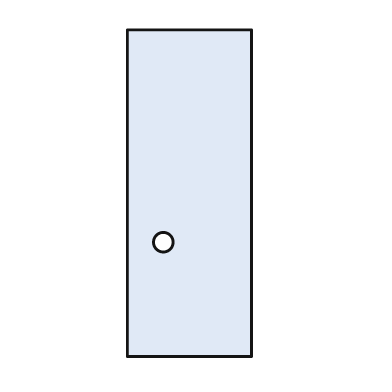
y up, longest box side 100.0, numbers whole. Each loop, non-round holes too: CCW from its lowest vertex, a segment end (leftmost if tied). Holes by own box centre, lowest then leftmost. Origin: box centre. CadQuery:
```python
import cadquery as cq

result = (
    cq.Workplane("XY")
    .moveTo(-19.0, -50.0)
    .lineTo(19.0, -50.0)
    .lineTo(19.0, 50.0)
    .lineTo(-19.0, 50.0)
    .close()
    .moveTo(-8.0, -15.0)
    .circle(3.0)
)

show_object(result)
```